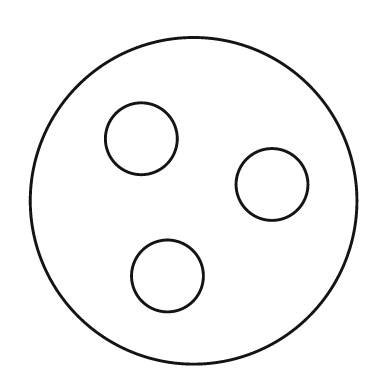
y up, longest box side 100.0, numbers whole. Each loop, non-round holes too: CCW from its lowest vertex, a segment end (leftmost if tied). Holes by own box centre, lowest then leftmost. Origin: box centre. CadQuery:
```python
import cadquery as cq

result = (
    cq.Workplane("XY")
    .moveTo(0.0, 0.0)
    .circle(50.0)
    .moveTo(-8.0, -23.0)
    .circle(11.0)
    .moveTo(24.0, 5.0)
    .circle(11.0)
    .moveTo(-16.0, 19.0)
    .circle(11.0)
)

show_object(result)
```